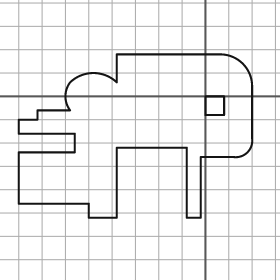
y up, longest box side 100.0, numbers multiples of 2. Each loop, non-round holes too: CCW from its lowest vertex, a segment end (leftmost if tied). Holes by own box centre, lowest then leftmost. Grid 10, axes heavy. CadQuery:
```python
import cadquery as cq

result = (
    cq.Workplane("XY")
    .moveTo(-50.0, -52.0)
    .lineTo(-38.0, -52.0)
    .lineTo(-38.0, -22.0)
    .lineTo(-8.0, -22.0)
    .lineTo(-8.0, -52.0)
    .lineTo(-2.0, -52.0)
    .lineTo(-2.0, -26.0)
    .lineTo(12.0, -26.0)
    .threePointArc((18.0, -24.0), (20.0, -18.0))
    .lineTo(20.0, 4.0)
    .threePointArc((16.0, 14.0), (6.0, 18.0))
    .lineTo(-38.0, 18.0)
    .lineTo(-38.0, 6.0)
    .threePointArc((-48.0, 10.0), (-58.0, 6.0))
    .threePointArc((-60.0, 0.0), (-58.0, -6.0))
    .lineTo(-72.0, -6.0)
    .lineTo(-72.0, -10.0)
    .lineTo(-80.0, -10.0)
    .lineTo(-80.0, -16.0)
    .lineTo(-56.0, -16.0)
    .lineTo(-56.0, -24.0)
    .lineTo(-80.0, -24.0)
    .lineTo(-80.0, -46.0)
    .lineTo(-50.0, -46.0)
    .close()
    .moveTo(0.0, -8.0)
    .lineTo(8.0, -8.0)
    .lineTo(8.0, 0.0)
    .lineTo(0.0, 0.0)
    .close()
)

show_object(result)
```